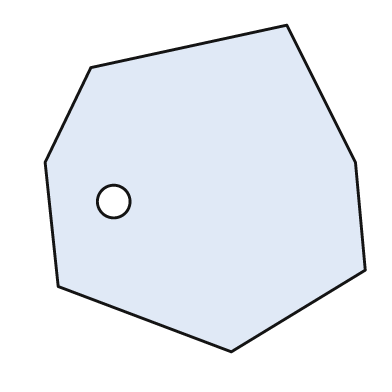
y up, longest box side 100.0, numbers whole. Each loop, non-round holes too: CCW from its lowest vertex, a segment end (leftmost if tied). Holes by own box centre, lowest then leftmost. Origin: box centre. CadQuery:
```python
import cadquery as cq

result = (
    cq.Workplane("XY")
    .moveTo(8.0, -50.0)
    .lineTo(49.0, -25.0)
    .lineTo(46.0, 8.0)
    .lineTo(25.0, 50.0)
    .lineTo(-35.0, 37.0)
    .lineTo(-49.0, 8.0)
    .lineTo(-45.0, -30.0)
    .close()
    .moveTo(-28.0, -4.0)
    .circle(5.0)
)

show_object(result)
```